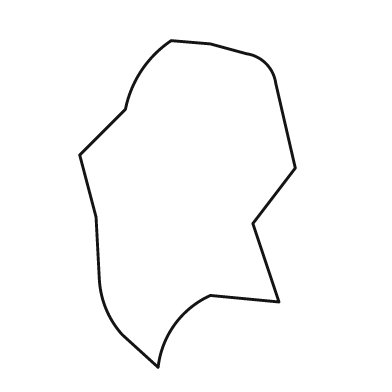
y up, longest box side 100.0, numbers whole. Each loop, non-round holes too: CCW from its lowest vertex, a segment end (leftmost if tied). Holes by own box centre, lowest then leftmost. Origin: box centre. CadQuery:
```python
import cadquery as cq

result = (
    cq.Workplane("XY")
    .moveTo(-9.0, -50.0)
    .threePointArc((-4.0, -37.0), (7.0, -28.0))
    .lineTo(28.0, -30.0)
    .lineTo(20.0, -6.0)
    .lineTo(33.0, 11.0)
    .lineTo(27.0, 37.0)
    .threePointArc((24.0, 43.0), (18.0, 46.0))
    .lineTo(7.0, 49.0)
    .lineTo(-5.0, 50.0)
    .threePointArc((-14.0, 41.0), (-19.0, 29.0))
    .lineTo(-33.0, 15.0)
    .lineTo(-28.0, -4.0)
    .lineTo(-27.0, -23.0)
    .threePointArc((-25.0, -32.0), (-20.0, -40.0))
    .close()
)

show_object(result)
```